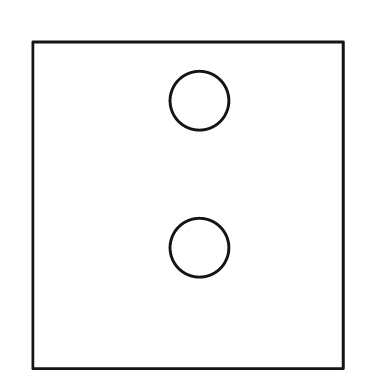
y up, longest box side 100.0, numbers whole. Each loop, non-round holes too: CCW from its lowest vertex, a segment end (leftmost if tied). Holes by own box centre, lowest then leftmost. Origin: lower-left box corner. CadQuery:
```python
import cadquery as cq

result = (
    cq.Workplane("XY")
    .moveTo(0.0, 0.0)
    .lineTo(95.0, 0.0)
    .lineTo(95.0, 100.0)
    .lineTo(0.0, 100.0)
    .close()
    .moveTo(51.0, 37.0)
    .circle(9.0)
    .moveTo(51.0, 82.0)
    .circle(9.0)
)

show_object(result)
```